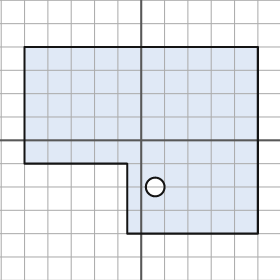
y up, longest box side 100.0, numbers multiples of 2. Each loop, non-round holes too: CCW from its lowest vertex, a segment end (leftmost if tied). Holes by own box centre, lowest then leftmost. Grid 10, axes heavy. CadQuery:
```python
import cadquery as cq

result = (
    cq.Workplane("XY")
    .moveTo(-6.0, -40.0)
    .lineTo(50.0, -40.0)
    .lineTo(50.0, 40.0)
    .lineTo(-50.0, 40.0)
    .lineTo(-50.0, -10.0)
    .lineTo(-6.0, -10.0)
    .close()
    .moveTo(6.0, -20.0)
    .circle(4.0)
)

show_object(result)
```